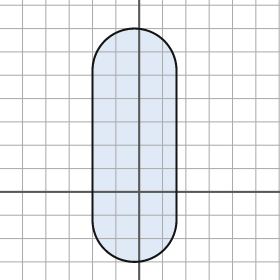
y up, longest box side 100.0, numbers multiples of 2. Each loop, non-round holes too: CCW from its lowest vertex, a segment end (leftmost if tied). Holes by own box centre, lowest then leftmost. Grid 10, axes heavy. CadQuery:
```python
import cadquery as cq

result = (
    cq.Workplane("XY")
    .moveTo(-20.0, -12.0)
    .threePointArc((-2.0, -30.0), (16.0, -12.0))
    .lineTo(16.0, 52.0)
    .threePointArc((-2.0, 70.0), (-20.0, 52.0))
    .close()
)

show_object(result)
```